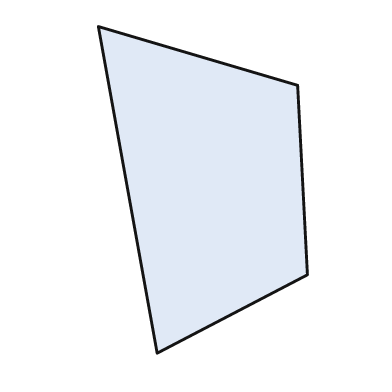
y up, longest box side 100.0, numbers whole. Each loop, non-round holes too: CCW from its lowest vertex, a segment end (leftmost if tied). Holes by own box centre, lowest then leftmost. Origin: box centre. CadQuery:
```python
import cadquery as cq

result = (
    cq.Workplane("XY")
    .moveTo(-14.0, -50.0)
    .lineTo(32.0, -26.0)
    .lineTo(29.0, 32.0)
    .lineTo(-32.0, 50.0)
    .close()
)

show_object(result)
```